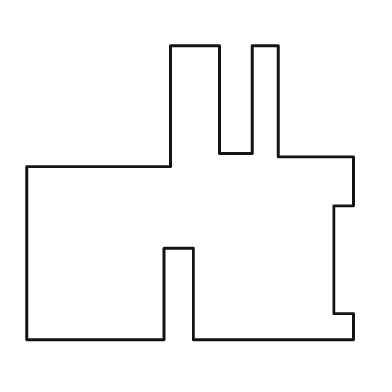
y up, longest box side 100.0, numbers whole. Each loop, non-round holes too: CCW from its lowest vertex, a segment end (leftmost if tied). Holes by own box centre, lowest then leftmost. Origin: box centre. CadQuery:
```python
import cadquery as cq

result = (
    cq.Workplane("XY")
    .moveTo(-50.0, -45.0)
    .lineTo(-8.0, -45.0)
    .lineTo(-8.0, -17.0)
    .lineTo(1.0, -17.0)
    .lineTo(1.0, -45.0)
    .lineTo(50.0, -45.0)
    .lineTo(50.0, -37.0)
    .lineTo(44.0, -37.0)
    .lineTo(44.0, -4.0)
    .lineTo(50.0, -4.0)
    .lineTo(50.0, 11.0)
    .lineTo(27.0, 11.0)
    .lineTo(27.0, 45.0)
    .lineTo(19.0, 45.0)
    .lineTo(19.0, 12.0)
    .lineTo(9.0, 12.0)
    .lineTo(9.0, 45.0)
    .lineTo(-6.0, 45.0)
    .lineTo(-6.0, 8.0)
    .lineTo(-50.0, 8.0)
    .close()
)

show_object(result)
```